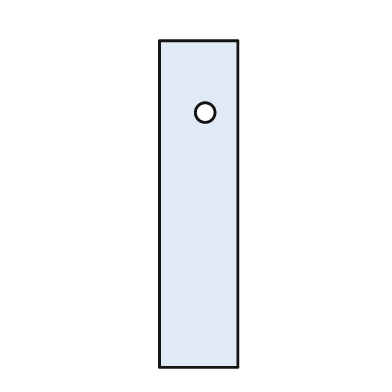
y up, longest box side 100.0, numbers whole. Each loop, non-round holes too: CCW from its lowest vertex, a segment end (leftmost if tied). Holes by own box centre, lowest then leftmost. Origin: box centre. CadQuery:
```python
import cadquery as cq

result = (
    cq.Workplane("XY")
    .moveTo(-12.0, -50.0)
    .lineTo(12.0, -50.0)
    .lineTo(12.0, 50.0)
    .lineTo(-12.0, 50.0)
    .close()
    .moveTo(2.0, 28.0)
    .circle(3.0)
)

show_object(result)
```